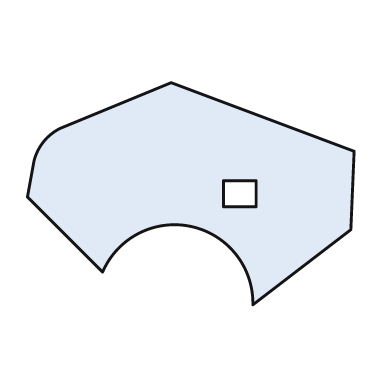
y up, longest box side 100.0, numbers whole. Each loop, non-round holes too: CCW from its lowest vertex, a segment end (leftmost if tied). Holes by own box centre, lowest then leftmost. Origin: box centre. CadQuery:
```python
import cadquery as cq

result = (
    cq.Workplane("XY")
    .moveTo(19.0, -34.0)
    .lineTo(49.0, -11.0)
    .lineTo(50.0, 13.0)
    .lineTo(-6.0, 34.0)
    .lineTo(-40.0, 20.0)
    .threePointArc((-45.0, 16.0), (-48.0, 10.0))
    .lineTo(-50.0, -1.0)
    .lineTo(-27.0, -24.0)
    .threePointArc((0.0, -10.0), (19.0, -34.0))
    .close()
    .moveTo(10.0, -4.0)
    .lineTo(20.0, -4.0)
    .lineTo(20.0, 4.0)
    .lineTo(10.0, 4.0)
    .close()
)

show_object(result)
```